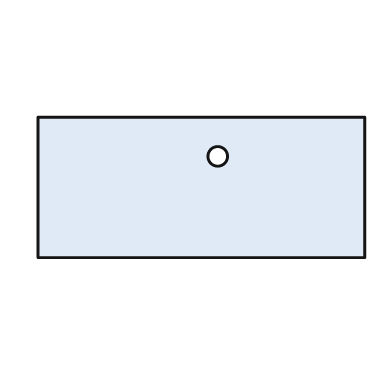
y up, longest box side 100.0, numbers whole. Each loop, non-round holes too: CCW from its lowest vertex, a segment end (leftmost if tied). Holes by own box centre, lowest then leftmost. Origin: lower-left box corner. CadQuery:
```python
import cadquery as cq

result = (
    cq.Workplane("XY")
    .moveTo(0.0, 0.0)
    .lineTo(100.0, 0.0)
    .lineTo(100.0, 43.0)
    .lineTo(0.0, 43.0)
    .close()
    .moveTo(55.0, 31.0)
    .circle(3.0)
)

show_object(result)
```